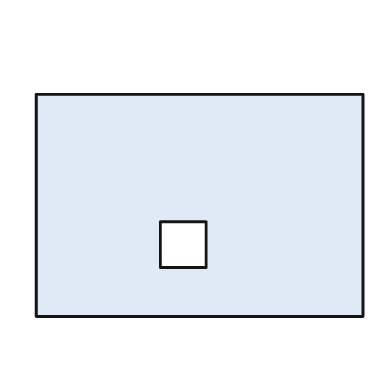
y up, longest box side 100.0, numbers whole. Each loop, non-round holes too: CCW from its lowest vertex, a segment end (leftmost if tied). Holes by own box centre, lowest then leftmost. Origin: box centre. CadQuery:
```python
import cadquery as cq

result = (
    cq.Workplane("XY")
    .moveTo(-50.0, -34.0)
    .lineTo(50.0, -34.0)
    .lineTo(50.0, 34.0)
    .lineTo(-50.0, 34.0)
    .close()
    .moveTo(-12.0, -19.0)
    .lineTo(2.0, -19.0)
    .lineTo(2.0, -5.0)
    .lineTo(-12.0, -5.0)
    .close()
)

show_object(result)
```